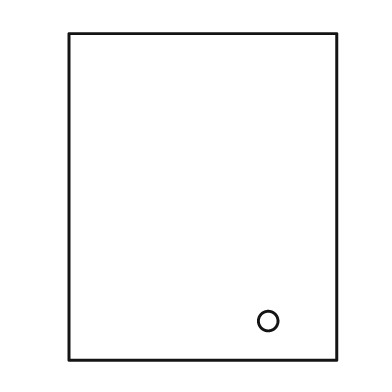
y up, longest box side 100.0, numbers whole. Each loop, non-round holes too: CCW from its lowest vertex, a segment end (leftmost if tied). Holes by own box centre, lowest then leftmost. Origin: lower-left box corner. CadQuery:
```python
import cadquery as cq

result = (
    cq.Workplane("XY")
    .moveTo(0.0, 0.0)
    .lineTo(82.0, 0.0)
    .lineTo(82.0, 100.0)
    .lineTo(0.0, 100.0)
    .close()
    .moveTo(61.0, 12.0)
    .circle(3.0)
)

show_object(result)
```